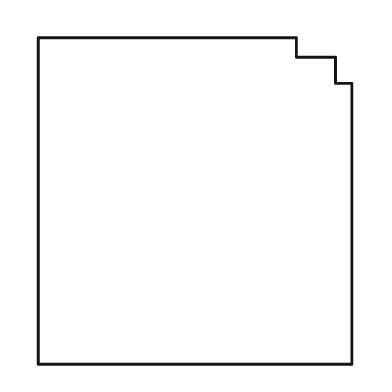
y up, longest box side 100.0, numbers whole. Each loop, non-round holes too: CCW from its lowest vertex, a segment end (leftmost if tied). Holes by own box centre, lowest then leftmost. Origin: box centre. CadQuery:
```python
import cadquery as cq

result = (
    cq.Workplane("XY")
    .moveTo(-48.0, -50.0)
    .lineTo(48.0, -50.0)
    .lineTo(48.0, 36.0)
    .lineTo(43.0, 36.0)
    .lineTo(43.0, 44.0)
    .lineTo(31.0, 44.0)
    .lineTo(31.0, 50.0)
    .lineTo(-48.0, 50.0)
    .close()
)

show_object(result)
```